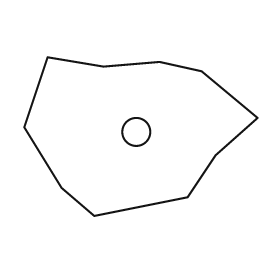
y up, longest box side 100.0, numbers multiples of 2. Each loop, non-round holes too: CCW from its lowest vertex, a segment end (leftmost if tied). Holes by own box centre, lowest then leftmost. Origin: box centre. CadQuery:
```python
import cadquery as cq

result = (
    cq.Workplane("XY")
    .moveTo(-20.0, -34.0)
    .lineTo(20.0, -26.0)
    .lineTo(32.0, -8.0)
    .lineTo(50.0, 8.0)
    .lineTo(26.0, 28.0)
    .lineTo(8.0, 32.0)
    .lineTo(-16.0, 30.0)
    .lineTo(-40.0, 34.0)
    .lineTo(-50.0, 4.0)
    .lineTo(-34.0, -22.0)
    .close()
    .moveTo(-2.0, 2.0)
    .circle(6.0)
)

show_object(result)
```